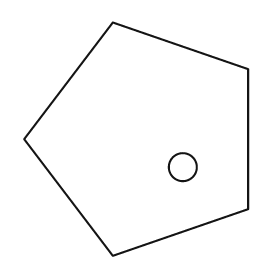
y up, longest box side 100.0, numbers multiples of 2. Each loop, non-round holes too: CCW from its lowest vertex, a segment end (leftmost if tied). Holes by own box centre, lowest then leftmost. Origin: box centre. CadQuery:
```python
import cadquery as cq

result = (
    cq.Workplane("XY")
    .moveTo(-10.0, -50.0)
    .lineTo(48.0, -30.0)
    .lineTo(48.0, 30.0)
    .lineTo(-10.0, 50.0)
    .lineTo(-48.0, 0.0)
    .close()
    .moveTo(20.0, -12.0)
    .circle(6.0)
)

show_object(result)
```